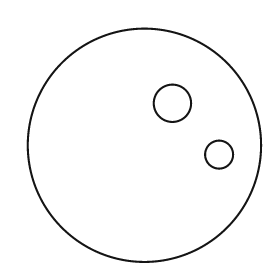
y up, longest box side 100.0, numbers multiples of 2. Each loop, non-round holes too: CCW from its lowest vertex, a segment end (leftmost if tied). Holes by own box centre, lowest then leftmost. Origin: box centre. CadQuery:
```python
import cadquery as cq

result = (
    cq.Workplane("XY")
    .moveTo(0.0, 0.0)
    .circle(50.0)
    .moveTo(32.0, -4.0)
    .circle(6.0)
    .moveTo(12.0, 18.0)
    .circle(8.0)
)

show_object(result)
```